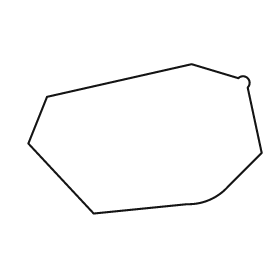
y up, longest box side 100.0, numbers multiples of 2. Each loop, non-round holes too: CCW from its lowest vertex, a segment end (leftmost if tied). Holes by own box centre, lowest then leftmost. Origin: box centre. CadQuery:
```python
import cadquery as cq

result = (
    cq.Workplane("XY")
    .moveTo(-22.0, -32.0)
    .lineTo(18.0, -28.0)
    .threePointArc((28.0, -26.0), (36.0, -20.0))
    .lineTo(50.0, -6.0)
    .lineTo(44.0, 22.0)
    .threePointArc((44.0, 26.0), (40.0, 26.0))
    .lineTo(20.0, 32.0)
    .lineTo(-42.0, 18.0)
    .lineTo(-50.0, -2.0)
    .close()
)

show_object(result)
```